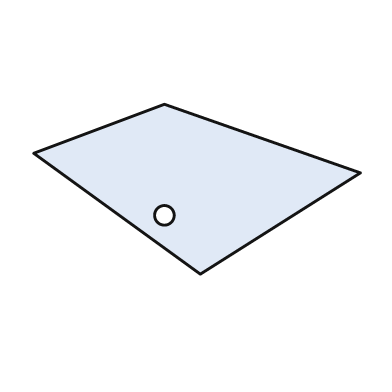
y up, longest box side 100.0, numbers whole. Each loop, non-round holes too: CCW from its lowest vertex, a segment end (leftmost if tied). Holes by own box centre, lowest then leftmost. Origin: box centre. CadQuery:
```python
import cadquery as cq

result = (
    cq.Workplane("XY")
    .moveTo(1.0, -26.0)
    .lineTo(50.0, 5.0)
    .lineTo(-10.0, 26.0)
    .lineTo(-50.0, 11.0)
    .close()
    .moveTo(-10.0, -8.0)
    .circle(3.0)
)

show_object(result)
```